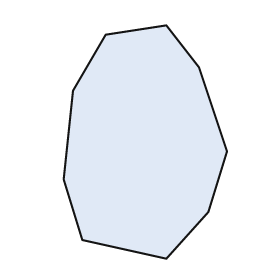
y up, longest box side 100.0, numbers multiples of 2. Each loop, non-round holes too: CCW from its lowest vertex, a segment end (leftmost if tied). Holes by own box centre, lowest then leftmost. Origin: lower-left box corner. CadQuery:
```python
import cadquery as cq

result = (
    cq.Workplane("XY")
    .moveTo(44.0, 0.0)
    .lineTo(62.0, 20.0)
    .lineTo(70.0, 46.0)
    .lineTo(58.0, 82.0)
    .lineTo(44.0, 100.0)
    .lineTo(18.0, 96.0)
    .lineTo(4.0, 72.0)
    .lineTo(0.0, 34.0)
    .lineTo(8.0, 8.0)
    .close()
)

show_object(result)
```